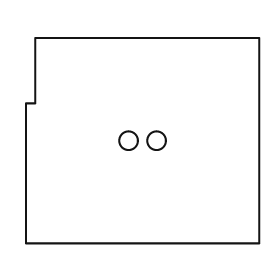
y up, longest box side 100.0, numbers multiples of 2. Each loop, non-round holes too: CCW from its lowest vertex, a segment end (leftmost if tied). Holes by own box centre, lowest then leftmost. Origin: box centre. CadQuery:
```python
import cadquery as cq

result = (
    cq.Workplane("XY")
    .moveTo(-50.0, -44.0)
    .lineTo(50.0, -44.0)
    .lineTo(50.0, 44.0)
    .lineTo(-46.0, 44.0)
    .lineTo(-46.0, 16.0)
    .lineTo(-50.0, 16.0)
    .close()
    .moveTo(-6.0, 0.0)
    .circle(4.0)
    .moveTo(6.0, 0.0)
    .circle(4.0)
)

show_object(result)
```